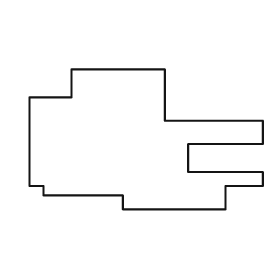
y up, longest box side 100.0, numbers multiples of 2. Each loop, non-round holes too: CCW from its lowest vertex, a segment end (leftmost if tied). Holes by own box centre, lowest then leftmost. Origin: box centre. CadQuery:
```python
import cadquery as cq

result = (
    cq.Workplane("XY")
    .moveTo(-10.0, -30.0)
    .lineTo(34.0, -30.0)
    .lineTo(34.0, -20.0)
    .lineTo(50.0, -20.0)
    .lineTo(50.0, -14.0)
    .lineTo(18.0, -14.0)
    .lineTo(18.0, -2.0)
    .lineTo(50.0, -2.0)
    .lineTo(50.0, 8.0)
    .lineTo(8.0, 8.0)
    .lineTo(8.0, 30.0)
    .lineTo(-32.0, 30.0)
    .lineTo(-32.0, 18.0)
    .lineTo(-50.0, 18.0)
    .lineTo(-50.0, -20.0)
    .lineTo(-44.0, -20.0)
    .lineTo(-44.0, -24.0)
    .lineTo(-10.0, -24.0)
    .close()
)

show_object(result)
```